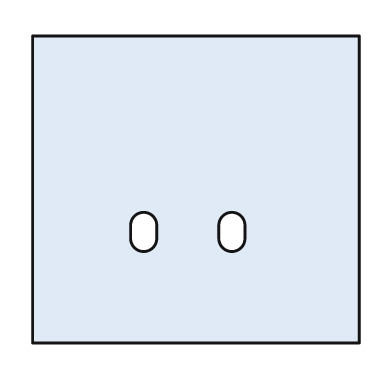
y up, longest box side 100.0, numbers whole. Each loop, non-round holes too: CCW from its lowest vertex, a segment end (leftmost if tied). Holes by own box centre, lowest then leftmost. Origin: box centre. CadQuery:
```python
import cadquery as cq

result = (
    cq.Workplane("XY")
    .moveTo(-50.0, -47.0)
    .lineTo(50.0, -47.0)
    .lineTo(50.0, 47.0)
    .lineTo(-50.0, 47.0)
    .close()
    .moveTo(-20.0, -15.0)
    .threePointArc((-16.0, -19.0), (-12.0, -15.0))
    .lineTo(-12.0, -11.0)
    .threePointArc((-16.0, -7.0), (-20.0, -11.0))
    .close()
    .moveTo(7.0, -15.0)
    .threePointArc((11.0, -19.0), (15.0, -15.0))
    .lineTo(15.0, -11.0)
    .threePointArc((11.0, -7.0), (7.0, -11.0))
    .close()
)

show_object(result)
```